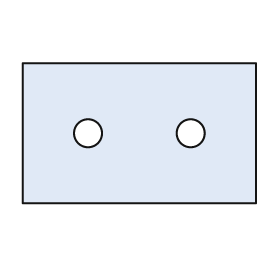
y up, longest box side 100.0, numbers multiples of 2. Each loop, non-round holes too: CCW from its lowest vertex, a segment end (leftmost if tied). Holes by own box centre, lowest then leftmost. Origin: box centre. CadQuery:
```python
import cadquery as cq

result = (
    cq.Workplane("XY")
    .moveTo(-50.0, -30.0)
    .lineTo(50.0, -30.0)
    .lineTo(50.0, 30.0)
    .lineTo(-50.0, 30.0)
    .close()
    .moveTo(-22.0, 0.0)
    .circle(6.0)
    .moveTo(22.0, 0.0)
    .circle(6.0)
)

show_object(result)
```